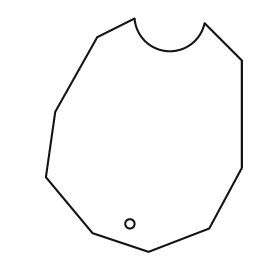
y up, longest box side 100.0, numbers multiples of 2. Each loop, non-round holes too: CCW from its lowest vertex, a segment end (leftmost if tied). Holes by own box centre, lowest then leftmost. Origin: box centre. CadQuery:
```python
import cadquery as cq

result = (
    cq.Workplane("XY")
    .moveTo(2.0, -50.0)
    .lineTo(28.0, -40.0)
    .lineTo(42.0, -14.0)
    .lineTo(42.0, 32.0)
    .lineTo(26.0, 48.0)
    .threePointArc((10.0, 36.0), (-4.0, 50.0))
    .lineTo(-20.0, 42.0)
    .lineTo(-38.0, 10.0)
    .lineTo(-42.0, -18.0)
    .lineTo(-22.0, -42.0)
    .close()
    .moveTo(-6.0, -38.0)
    .circle(2.0)
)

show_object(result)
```